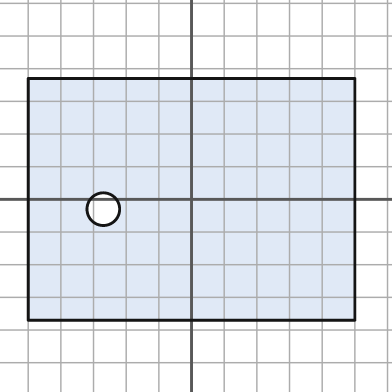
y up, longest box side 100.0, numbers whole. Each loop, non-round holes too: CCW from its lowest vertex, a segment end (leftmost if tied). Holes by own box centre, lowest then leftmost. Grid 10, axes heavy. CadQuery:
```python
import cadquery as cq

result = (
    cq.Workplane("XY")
    .moveTo(-50.0, -37.0)
    .lineTo(50.0, -37.0)
    .lineTo(50.0, 37.0)
    .lineTo(-50.0, 37.0)
    .close()
    .moveTo(-27.0, -3.0)
    .circle(5.0)
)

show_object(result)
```